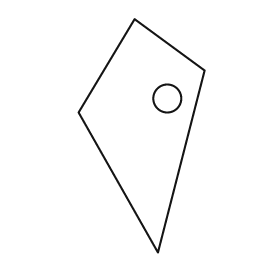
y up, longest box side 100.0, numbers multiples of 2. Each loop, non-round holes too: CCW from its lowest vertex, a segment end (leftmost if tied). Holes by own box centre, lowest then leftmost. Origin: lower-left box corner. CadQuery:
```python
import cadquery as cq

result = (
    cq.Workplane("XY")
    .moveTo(34.0, 0.0)
    .lineTo(54.0, 78.0)
    .lineTo(24.0, 100.0)
    .lineTo(0.0, 60.0)
    .close()
    .moveTo(38.0, 66.0)
    .circle(6.0)
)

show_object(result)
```